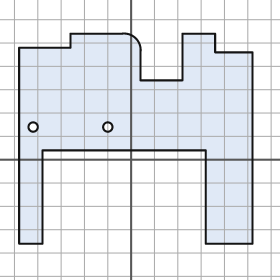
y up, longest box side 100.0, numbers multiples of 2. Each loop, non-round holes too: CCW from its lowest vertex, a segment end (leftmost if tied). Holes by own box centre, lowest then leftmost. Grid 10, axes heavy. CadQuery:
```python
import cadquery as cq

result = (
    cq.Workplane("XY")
    .moveTo(-48.0, -36.0)
    .lineTo(-38.0, -36.0)
    .lineTo(-38.0, 4.0)
    .lineTo(32.0, 4.0)
    .lineTo(32.0, -36.0)
    .lineTo(52.0, -36.0)
    .lineTo(52.0, 46.0)
    .lineTo(36.0, 46.0)
    .lineTo(36.0, 54.0)
    .lineTo(22.0, 54.0)
    .lineTo(22.0, 34.0)
    .lineTo(4.0, 34.0)
    .lineTo(4.0, 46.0)
    .threePointArc((2.0, 52.0), (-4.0, 54.0))
    .lineTo(-26.0, 54.0)
    .lineTo(-26.0, 48.0)
    .lineTo(-48.0, 48.0)
    .close()
    .moveTo(-42.0, 14.0)
    .circle(2.0)
    .moveTo(-10.0, 14.0)
    .circle(2.0)
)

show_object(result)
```